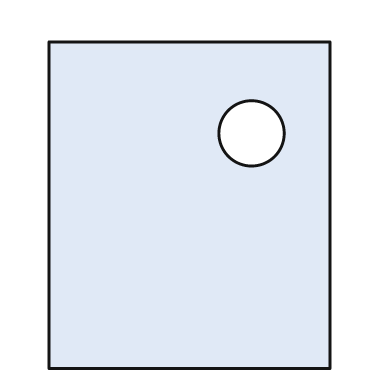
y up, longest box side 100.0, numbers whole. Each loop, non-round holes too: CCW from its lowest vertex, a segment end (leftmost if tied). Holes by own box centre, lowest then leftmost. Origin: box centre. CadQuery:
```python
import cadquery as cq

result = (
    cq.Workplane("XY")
    .moveTo(-43.0, -50.0)
    .lineTo(43.0, -50.0)
    .lineTo(43.0, 50.0)
    .lineTo(-43.0, 50.0)
    .close()
    .moveTo(19.0, 22.0)
    .circle(10.0)
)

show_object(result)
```